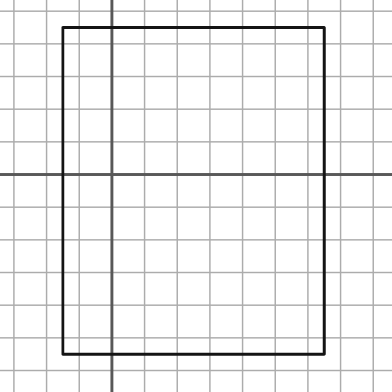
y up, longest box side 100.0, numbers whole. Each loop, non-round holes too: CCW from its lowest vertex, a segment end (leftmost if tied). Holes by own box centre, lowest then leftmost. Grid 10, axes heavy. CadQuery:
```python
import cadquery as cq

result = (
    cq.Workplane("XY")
    .moveTo(-15.0, -55.0)
    .lineTo(65.0, -55.0)
    .lineTo(65.0, 45.0)
    .lineTo(-15.0, 45.0)
    .close()
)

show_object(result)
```